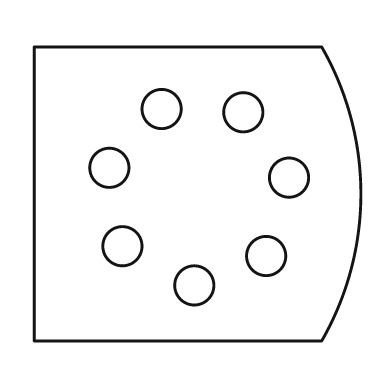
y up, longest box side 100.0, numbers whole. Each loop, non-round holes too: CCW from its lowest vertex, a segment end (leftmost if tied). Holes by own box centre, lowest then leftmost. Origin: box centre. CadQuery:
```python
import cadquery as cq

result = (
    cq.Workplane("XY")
    .moveTo(-50.0, -45.0)
    .lineTo(38.0, -45.0)
    .threePointArc((50.0, 0.0), (38.0, 45.0))
    .lineTo(-50.0, 45.0)
    .close()
    .moveTo(-1.0, -28.0)
    .circle(6.0)
    .moveTo(21.0, -19.0)
    .circle(6.0)
    .moveTo(-23.0, -16.0)
    .circle(6.0)
    .moveTo(28.0, 5.0)
    .circle(6.0)
    .moveTo(-27.0, 8.0)
    .circle(6.0)
    .moveTo(14.0, 25.0)
    .circle(6.0)
    .moveTo(-11.0, 26.0)
    .circle(6.0)
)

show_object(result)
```